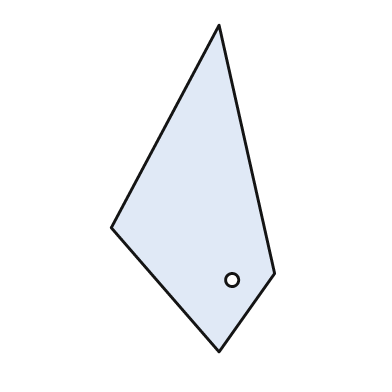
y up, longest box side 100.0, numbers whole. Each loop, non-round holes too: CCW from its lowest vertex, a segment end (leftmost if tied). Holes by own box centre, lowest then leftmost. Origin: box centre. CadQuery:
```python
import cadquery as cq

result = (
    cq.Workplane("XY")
    .moveTo(8.0, -50.0)
    .lineTo(25.0, -26.0)
    .lineTo(8.0, 50.0)
    .lineTo(-25.0, -12.0)
    .close()
    .moveTo(12.0, -28.0)
    .circle(2.0)
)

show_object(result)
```